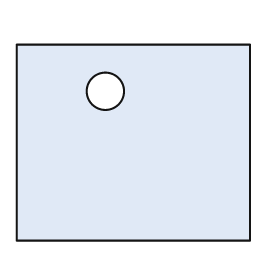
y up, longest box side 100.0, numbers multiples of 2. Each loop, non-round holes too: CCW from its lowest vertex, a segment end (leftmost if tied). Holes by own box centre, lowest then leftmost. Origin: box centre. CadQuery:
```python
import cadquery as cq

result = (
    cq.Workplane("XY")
    .moveTo(-50.0, -42.0)
    .lineTo(50.0, -42.0)
    .lineTo(50.0, 42.0)
    .lineTo(-50.0, 42.0)
    .close()
    .moveTo(-12.0, 22.0)
    .circle(8.0)
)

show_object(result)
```